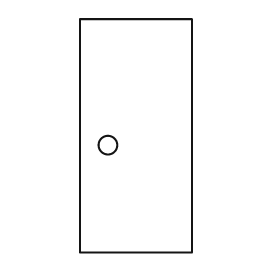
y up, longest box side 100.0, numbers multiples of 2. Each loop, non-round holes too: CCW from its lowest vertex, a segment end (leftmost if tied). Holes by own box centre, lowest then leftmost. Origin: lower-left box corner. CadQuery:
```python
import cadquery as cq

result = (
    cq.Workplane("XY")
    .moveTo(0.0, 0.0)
    .lineTo(48.0, 0.0)
    .lineTo(48.0, 100.0)
    .lineTo(0.0, 100.0)
    .close()
    .moveTo(12.0, 46.0)
    .circle(4.0)
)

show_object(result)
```